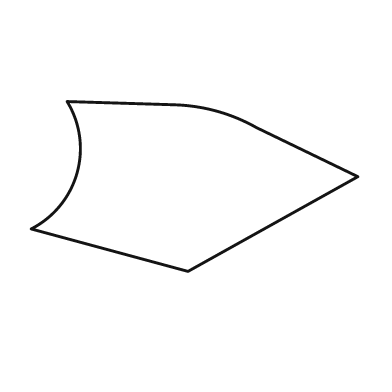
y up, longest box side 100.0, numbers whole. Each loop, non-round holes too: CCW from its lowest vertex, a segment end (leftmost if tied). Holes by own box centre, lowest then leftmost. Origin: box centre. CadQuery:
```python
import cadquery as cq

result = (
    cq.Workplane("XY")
    .moveTo(-2.0, -26.0)
    .lineTo(50.0, 3.0)
    .lineTo(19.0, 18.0)
    .threePointArc((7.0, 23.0), (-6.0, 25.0))
    .lineTo(-39.0, 26.0)
    .threePointArc((-36.0, 4.0), (-50.0, -13.0))
    .close()
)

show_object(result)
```